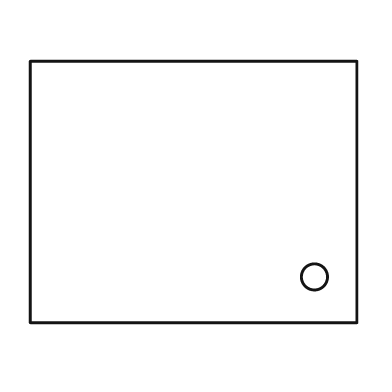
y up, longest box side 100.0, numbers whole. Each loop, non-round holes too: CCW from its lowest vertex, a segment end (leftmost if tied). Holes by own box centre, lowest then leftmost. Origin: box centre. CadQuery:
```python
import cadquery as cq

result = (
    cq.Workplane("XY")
    .moveTo(-50.0, -40.0)
    .lineTo(50.0, -40.0)
    .lineTo(50.0, 40.0)
    .lineTo(-50.0, 40.0)
    .close()
    .moveTo(37.0, -26.0)
    .circle(4.0)
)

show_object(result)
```